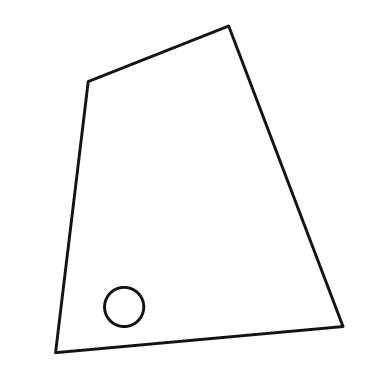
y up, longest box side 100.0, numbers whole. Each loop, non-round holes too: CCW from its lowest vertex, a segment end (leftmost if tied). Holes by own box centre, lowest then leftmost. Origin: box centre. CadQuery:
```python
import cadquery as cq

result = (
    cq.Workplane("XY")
    .moveTo(-44.0, -50.0)
    .lineTo(44.0, -42.0)
    .lineTo(9.0, 50.0)
    .lineTo(-34.0, 33.0)
    .close()
    .moveTo(-23.0, -36.0)
    .circle(6.0)
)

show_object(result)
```